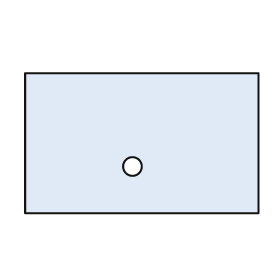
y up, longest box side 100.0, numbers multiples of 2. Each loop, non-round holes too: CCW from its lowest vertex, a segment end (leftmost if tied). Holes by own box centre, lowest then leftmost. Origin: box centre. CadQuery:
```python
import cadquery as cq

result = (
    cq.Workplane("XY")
    .moveTo(-50.0, -30.0)
    .lineTo(50.0, -30.0)
    .lineTo(50.0, 30.0)
    .lineTo(-50.0, 30.0)
    .close()
    .moveTo(-4.0, -10.0)
    .circle(4.0)
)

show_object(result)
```